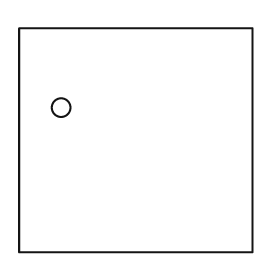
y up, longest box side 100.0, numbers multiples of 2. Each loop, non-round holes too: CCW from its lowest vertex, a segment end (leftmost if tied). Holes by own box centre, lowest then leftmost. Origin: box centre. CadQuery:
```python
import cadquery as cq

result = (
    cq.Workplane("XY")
    .moveTo(-50.0, -48.0)
    .lineTo(50.0, -48.0)
    .lineTo(50.0, 48.0)
    .lineTo(-50.0, 48.0)
    .close()
    .moveTo(-32.0, 14.0)
    .circle(4.0)
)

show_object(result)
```